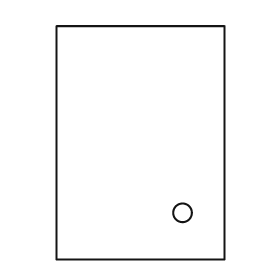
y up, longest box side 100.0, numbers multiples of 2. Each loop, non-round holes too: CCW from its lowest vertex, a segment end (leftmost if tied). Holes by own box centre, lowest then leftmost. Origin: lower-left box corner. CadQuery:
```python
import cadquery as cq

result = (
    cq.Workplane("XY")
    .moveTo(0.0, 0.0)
    .lineTo(72.0, 0.0)
    .lineTo(72.0, 100.0)
    .lineTo(0.0, 100.0)
    .close()
    .moveTo(54.0, 20.0)
    .circle(4.0)
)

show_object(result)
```